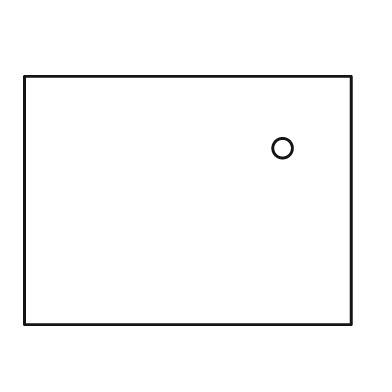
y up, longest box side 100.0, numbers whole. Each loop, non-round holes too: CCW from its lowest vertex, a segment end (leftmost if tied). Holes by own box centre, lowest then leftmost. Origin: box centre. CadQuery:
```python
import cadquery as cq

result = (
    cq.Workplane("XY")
    .moveTo(-50.0, -38.0)
    .lineTo(50.0, -38.0)
    .lineTo(50.0, 38.0)
    .lineTo(-50.0, 38.0)
    .close()
    .moveTo(29.0, 16.0)
    .circle(3.0)
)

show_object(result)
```